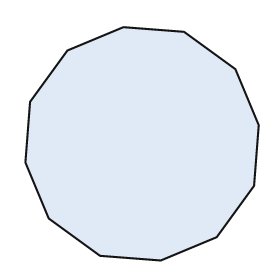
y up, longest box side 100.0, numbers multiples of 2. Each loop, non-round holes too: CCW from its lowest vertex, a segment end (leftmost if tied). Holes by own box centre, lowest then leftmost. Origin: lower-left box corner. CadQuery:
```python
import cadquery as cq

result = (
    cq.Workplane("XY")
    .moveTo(58.0, 0.0)
    .lineTo(82.0, 10.0)
    .lineTo(98.0, 32.0)
    .lineTo(100.0, 58.0)
    .lineTo(90.0, 82.0)
    .lineTo(68.0, 98.0)
    .lineTo(42.0, 100.0)
    .lineTo(18.0, 90.0)
    .lineTo(2.0, 68.0)
    .lineTo(0.0, 42.0)
    .lineTo(10.0, 18.0)
    .lineTo(32.0, 2.0)
    .close()
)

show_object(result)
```